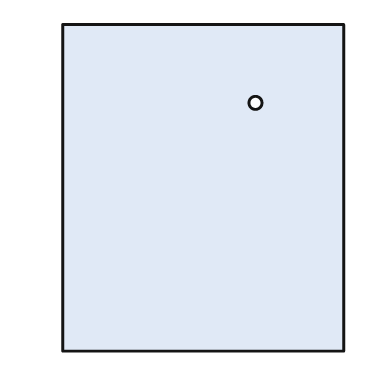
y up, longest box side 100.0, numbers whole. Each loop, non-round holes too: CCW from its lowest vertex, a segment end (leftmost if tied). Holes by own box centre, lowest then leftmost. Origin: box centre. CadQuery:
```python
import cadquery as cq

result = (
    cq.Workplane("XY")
    .moveTo(-43.0, -50.0)
    .lineTo(43.0, -50.0)
    .lineTo(43.0, 50.0)
    .lineTo(-43.0, 50.0)
    .close()
    .moveTo(16.0, 26.0)
    .circle(2.0)
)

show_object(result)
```